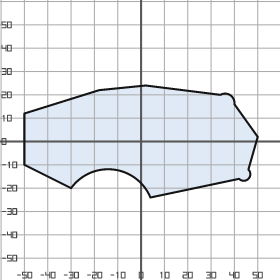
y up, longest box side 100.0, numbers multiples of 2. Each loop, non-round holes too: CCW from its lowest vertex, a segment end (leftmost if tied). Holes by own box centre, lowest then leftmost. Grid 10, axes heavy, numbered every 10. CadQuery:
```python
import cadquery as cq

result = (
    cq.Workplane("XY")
    .moveTo(4.0, -24.0)
    .lineTo(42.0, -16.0)
    .threePointArc((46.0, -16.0), (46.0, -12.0))
    .lineTo(50.0, 2.0)
    .lineTo(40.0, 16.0)
    .threePointArc((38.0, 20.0), (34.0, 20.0))
    .lineTo(2.0, 24.0)
    .lineTo(-18.0, 22.0)
    .lineTo(-50.0, 12.0)
    .lineTo(-50.0, -10.0)
    .lineTo(-30.0, -20.0)
    .threePointArc((-12.0, -12.0), (4.0, -24.0))
    .close()
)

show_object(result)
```